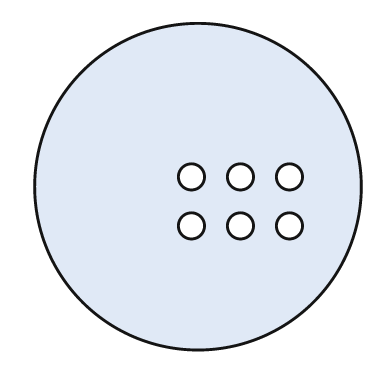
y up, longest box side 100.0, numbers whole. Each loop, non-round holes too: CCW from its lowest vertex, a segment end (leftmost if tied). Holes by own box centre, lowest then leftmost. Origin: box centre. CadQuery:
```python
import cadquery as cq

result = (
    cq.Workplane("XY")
    .moveTo(0.0, 0.0)
    .circle(50.0)
    .moveTo(-2.0, -12.0)
    .circle(4.0)
    .moveTo(13.0, -12.0)
    .circle(4.0)
    .moveTo(28.0, -12.0)
    .circle(4.0)
    .moveTo(-2.0, 3.0)
    .circle(4.0)
    .moveTo(13.0, 3.0)
    .circle(4.0)
    .moveTo(28.0, 3.0)
    .circle(4.0)
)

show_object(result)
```